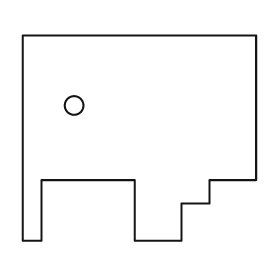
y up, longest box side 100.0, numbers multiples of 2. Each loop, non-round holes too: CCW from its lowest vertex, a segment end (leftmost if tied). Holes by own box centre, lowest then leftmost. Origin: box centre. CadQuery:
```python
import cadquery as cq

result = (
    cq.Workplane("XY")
    .moveTo(-50.0, -44.0)
    .lineTo(-42.0, -44.0)
    .lineTo(-42.0, -18.0)
    .lineTo(-2.0, -18.0)
    .lineTo(-2.0, -44.0)
    .lineTo(18.0, -44.0)
    .lineTo(18.0, -28.0)
    .lineTo(30.0, -28.0)
    .lineTo(30.0, -18.0)
    .lineTo(50.0, -18.0)
    .lineTo(50.0, 44.0)
    .lineTo(-50.0, 44.0)
    .close()
    .moveTo(-28.0, 14.0)
    .circle(4.0)
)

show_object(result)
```